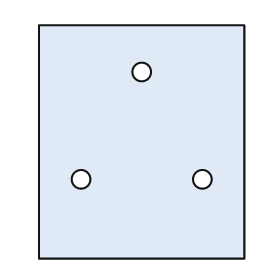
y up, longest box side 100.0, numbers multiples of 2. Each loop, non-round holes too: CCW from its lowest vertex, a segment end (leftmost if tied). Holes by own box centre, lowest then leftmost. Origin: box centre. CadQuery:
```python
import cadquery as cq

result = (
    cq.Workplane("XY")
    .moveTo(-44.0, -50.0)
    .lineTo(44.0, -50.0)
    .lineTo(44.0, 50.0)
    .lineTo(-44.0, 50.0)
    .close()
    .moveTo(-26.0, -16.0)
    .circle(4.0)
    .moveTo(26.0, -16.0)
    .circle(4.0)
    .moveTo(0.0, 30.0)
    .circle(4.0)
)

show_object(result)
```